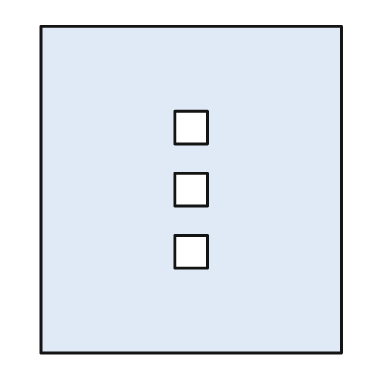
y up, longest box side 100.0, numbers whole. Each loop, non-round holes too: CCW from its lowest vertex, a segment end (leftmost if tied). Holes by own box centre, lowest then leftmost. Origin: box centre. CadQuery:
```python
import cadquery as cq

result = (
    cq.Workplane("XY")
    .moveTo(-46.0, -50.0)
    .lineTo(46.0, -50.0)
    .lineTo(46.0, 50.0)
    .lineTo(-46.0, 50.0)
    .close()
    .moveTo(-5.0, -24.0)
    .lineTo(5.0, -24.0)
    .lineTo(5.0, -14.0)
    .lineTo(-5.0, -14.0)
    .close()
    .moveTo(-5.0, -5.0)
    .lineTo(5.0, -5.0)
    .lineTo(5.0, 5.0)
    .lineTo(-5.0, 5.0)
    .close()
    .moveTo(-5.0, 14.0)
    .lineTo(5.0, 14.0)
    .lineTo(5.0, 24.0)
    .lineTo(-5.0, 24.0)
    .close()
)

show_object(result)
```